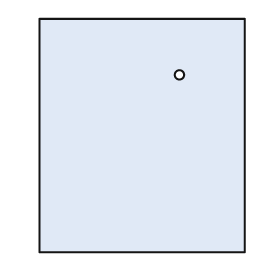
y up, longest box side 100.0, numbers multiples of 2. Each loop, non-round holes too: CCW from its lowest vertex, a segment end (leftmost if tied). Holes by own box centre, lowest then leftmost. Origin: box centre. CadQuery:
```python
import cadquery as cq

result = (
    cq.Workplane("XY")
    .moveTo(-44.0, -50.0)
    .lineTo(44.0, -50.0)
    .lineTo(44.0, 50.0)
    .lineTo(-44.0, 50.0)
    .close()
    .moveTo(16.0, 26.0)
    .circle(2.0)
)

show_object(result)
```